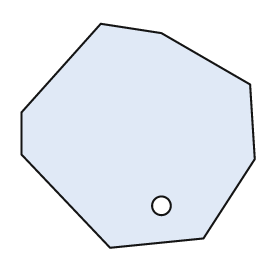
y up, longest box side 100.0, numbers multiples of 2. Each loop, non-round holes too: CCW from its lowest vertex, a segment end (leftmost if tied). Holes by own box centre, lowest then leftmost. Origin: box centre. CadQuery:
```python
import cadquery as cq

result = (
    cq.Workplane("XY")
    .moveTo(-12.0, -48.0)
    .lineTo(28.0, -44.0)
    .lineTo(50.0, -10.0)
    .lineTo(48.0, 22.0)
    .lineTo(10.0, 44.0)
    .lineTo(-16.0, 48.0)
    .lineTo(-50.0, 10.0)
    .lineTo(-50.0, -8.0)
    .close()
    .moveTo(10.0, -30.0)
    .circle(4.0)
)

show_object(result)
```